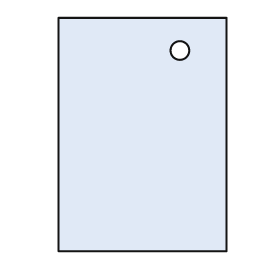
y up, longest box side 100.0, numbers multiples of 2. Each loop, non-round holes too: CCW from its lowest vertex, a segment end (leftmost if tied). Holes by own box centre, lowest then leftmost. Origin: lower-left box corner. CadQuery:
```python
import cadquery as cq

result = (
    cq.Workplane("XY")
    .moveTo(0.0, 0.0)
    .lineTo(72.0, 0.0)
    .lineTo(72.0, 100.0)
    .lineTo(0.0, 100.0)
    .close()
    .moveTo(52.0, 86.0)
    .circle(4.0)
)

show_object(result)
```